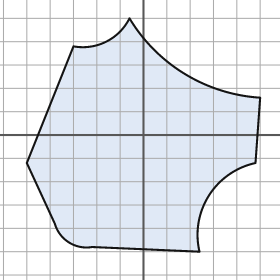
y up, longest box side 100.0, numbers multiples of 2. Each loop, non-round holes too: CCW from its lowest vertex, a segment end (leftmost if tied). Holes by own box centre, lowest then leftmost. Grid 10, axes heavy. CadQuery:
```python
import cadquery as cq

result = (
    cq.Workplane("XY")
    .moveTo(24.0, -50.0)
    .threePointArc((28.0, -26.0), (48.0, -12.0))
    .lineTo(50.0, 16.0)
    .threePointArc((18.0, 26.0), (-6.0, 50.0))
    .threePointArc((-16.0, 40.0), (-30.0, 38.0))
    .lineTo(-50.0, -12.0)
    .lineTo(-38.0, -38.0)
    .threePointArc((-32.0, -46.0), (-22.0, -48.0))
    .close()
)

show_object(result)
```